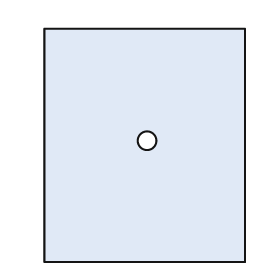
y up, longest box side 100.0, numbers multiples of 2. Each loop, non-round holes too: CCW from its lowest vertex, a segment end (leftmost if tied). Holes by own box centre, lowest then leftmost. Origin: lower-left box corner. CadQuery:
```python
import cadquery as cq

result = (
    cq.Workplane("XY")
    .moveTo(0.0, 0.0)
    .lineTo(86.0, 0.0)
    .lineTo(86.0, 100.0)
    .lineTo(0.0, 100.0)
    .close()
    .moveTo(44.0, 52.0)
    .circle(4.0)
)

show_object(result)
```